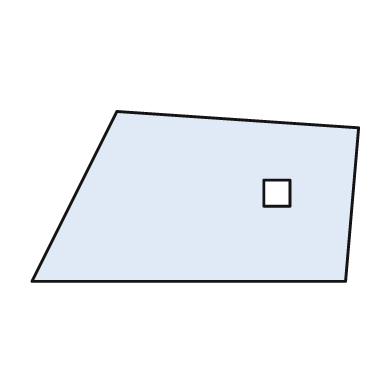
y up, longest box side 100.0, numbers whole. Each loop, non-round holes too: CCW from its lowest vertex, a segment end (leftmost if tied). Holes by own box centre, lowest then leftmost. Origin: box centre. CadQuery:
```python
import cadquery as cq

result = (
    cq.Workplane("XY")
    .moveTo(-50.0, -26.0)
    .lineTo(46.0, -26.0)
    .lineTo(50.0, 21.0)
    .lineTo(-24.0, 26.0)
    .close()
    .moveTo(21.0, -3.0)
    .lineTo(29.0, -3.0)
    .lineTo(29.0, 5.0)
    .lineTo(21.0, 5.0)
    .close()
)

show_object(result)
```